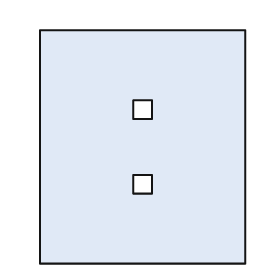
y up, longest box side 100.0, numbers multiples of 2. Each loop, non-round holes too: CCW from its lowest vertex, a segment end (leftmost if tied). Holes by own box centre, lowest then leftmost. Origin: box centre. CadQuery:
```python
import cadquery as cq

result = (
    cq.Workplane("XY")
    .moveTo(-44.0, -50.0)
    .lineTo(44.0, -50.0)
    .lineTo(44.0, 50.0)
    .lineTo(-44.0, 50.0)
    .close()
    .moveTo(-4.0, -20.0)
    .lineTo(4.0, -20.0)
    .lineTo(4.0, -12.0)
    .lineTo(-4.0, -12.0)
    .close()
    .moveTo(-4.0, 12.0)
    .lineTo(4.0, 12.0)
    .lineTo(4.0, 20.0)
    .lineTo(-4.0, 20.0)
    .close()
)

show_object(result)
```